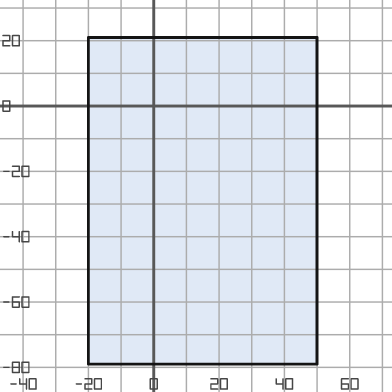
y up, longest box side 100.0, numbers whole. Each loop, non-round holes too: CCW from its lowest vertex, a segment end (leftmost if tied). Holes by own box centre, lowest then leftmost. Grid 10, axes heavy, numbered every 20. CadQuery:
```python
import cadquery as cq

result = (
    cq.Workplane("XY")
    .moveTo(-20.0, -79.0)
    .lineTo(50.0, -79.0)
    .lineTo(50.0, 21.0)
    .lineTo(-20.0, 21.0)
    .close()
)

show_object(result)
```